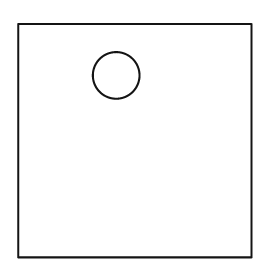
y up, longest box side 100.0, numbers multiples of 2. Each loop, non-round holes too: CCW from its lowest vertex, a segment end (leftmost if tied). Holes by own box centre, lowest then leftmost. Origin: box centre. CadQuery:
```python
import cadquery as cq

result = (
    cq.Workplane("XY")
    .moveTo(-50.0, -50.0)
    .lineTo(50.0, -50.0)
    .lineTo(50.0, 50.0)
    .lineTo(-50.0, 50.0)
    .close()
    .moveTo(-8.0, 28.0)
    .circle(10.0)
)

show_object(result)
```